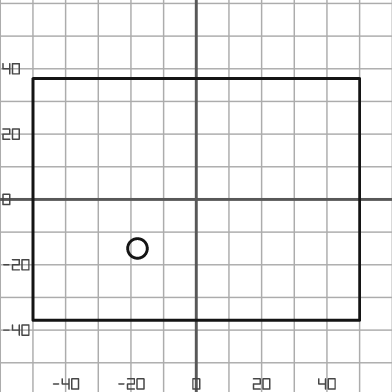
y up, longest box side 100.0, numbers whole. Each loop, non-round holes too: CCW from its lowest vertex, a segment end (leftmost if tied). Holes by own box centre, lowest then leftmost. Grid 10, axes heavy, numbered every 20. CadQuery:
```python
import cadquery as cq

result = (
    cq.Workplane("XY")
    .moveTo(-50.0, -37.0)
    .lineTo(50.0, -37.0)
    .lineTo(50.0, 37.0)
    .lineTo(-50.0, 37.0)
    .close()
    .moveTo(-18.0, -15.0)
    .circle(3.0)
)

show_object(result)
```